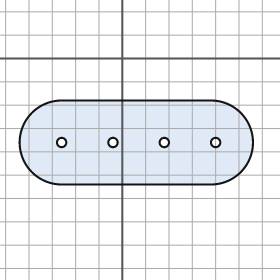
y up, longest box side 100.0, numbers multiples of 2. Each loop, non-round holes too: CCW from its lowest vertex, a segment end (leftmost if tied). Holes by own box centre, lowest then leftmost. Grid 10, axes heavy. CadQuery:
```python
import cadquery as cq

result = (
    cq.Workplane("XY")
    .moveTo(-26.0, -54.0)
    .lineTo(38.0, -54.0)
    .threePointArc((56.0, -36.0), (38.0, -18.0))
    .lineTo(-26.0, -18.0)
    .threePointArc((-44.0, -36.0), (-26.0, -54.0))
    .close()
    .moveTo(-26.0, -36.0)
    .circle(2.0)
    .moveTo(-4.0, -36.0)
    .circle(2.0)
    .moveTo(18.0, -36.0)
    .circle(2.0)
    .moveTo(40.0, -36.0)
    .circle(2.0)
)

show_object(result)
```